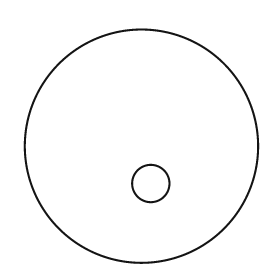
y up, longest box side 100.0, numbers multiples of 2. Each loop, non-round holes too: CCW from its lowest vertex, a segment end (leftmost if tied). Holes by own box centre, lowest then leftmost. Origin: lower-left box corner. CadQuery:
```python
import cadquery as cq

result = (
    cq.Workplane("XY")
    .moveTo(50.0, 50.0)
    .circle(50.0)
    .moveTo(54.0, 34.0)
    .circle(8.0)
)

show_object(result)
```